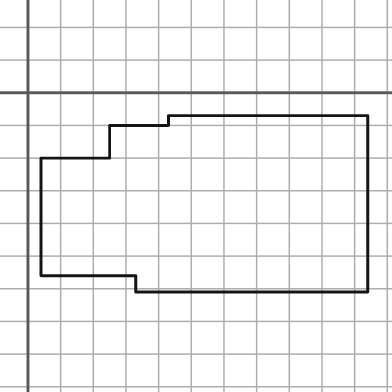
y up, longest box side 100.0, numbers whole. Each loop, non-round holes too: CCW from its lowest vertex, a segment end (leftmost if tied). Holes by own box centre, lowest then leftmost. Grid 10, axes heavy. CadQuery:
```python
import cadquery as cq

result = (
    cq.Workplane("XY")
    .moveTo(33.0, -61.0)
    .lineTo(104.0, -61.0)
    .lineTo(104.0, -7.0)
    .lineTo(43.0, -7.0)
    .lineTo(43.0, -10.0)
    .lineTo(25.0, -10.0)
    .lineTo(25.0, -20.0)
    .lineTo(4.0, -20.0)
    .lineTo(4.0, -56.0)
    .lineTo(33.0, -56.0)
    .close()
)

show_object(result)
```